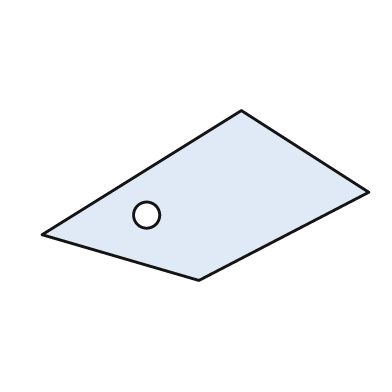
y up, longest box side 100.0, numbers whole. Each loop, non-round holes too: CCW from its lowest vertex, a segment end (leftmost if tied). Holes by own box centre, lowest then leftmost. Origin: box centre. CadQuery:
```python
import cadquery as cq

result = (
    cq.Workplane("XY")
    .moveTo(-2.0, -26.0)
    .lineTo(50.0, 1.0)
    .lineTo(11.0, 26.0)
    .lineTo(-50.0, -12.0)
    .close()
    .moveTo(-18.0, -6.0)
    .circle(4.0)
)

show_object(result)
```